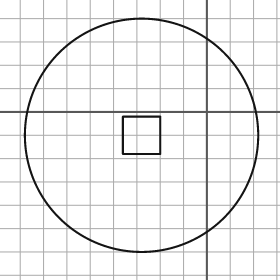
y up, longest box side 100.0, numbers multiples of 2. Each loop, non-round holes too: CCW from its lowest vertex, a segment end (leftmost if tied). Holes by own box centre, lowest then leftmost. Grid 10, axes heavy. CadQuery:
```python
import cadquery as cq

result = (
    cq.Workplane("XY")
    .moveTo(-28.0, -10.0)
    .circle(50.0)
    .moveTo(-36.0, -18.0)
    .lineTo(-20.0, -18.0)
    .lineTo(-20.0, -2.0)
    .lineTo(-36.0, -2.0)
    .close()
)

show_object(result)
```